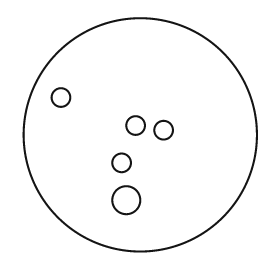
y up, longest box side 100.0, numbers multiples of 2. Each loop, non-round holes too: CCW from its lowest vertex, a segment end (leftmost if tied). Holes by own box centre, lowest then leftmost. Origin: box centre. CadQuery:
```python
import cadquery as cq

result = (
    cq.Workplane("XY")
    .moveTo(0.0, 0.0)
    .circle(50.0)
    .moveTo(-6.0, -28.0)
    .circle(6.0)
    .moveTo(-8.0, -12.0)
    .circle(4.0)
    .moveTo(10.0, 2.0)
    .circle(4.0)
    .moveTo(-2.0, 4.0)
    .circle(4.0)
    .moveTo(-34.0, 16.0)
    .circle(4.0)
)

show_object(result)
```